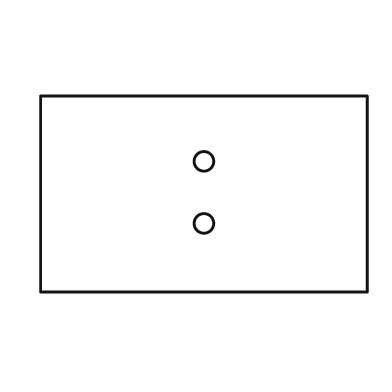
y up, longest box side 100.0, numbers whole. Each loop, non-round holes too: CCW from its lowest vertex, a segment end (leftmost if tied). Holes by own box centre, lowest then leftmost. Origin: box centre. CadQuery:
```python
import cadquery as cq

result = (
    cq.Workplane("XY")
    .moveTo(-50.0, -30.0)
    .lineTo(50.0, -30.0)
    .lineTo(50.0, 30.0)
    .lineTo(-50.0, 30.0)
    .close()
    .moveTo(0.0, -9.0)
    .circle(3.0)
    .moveTo(0.0, 10.0)
    .circle(3.0)
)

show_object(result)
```